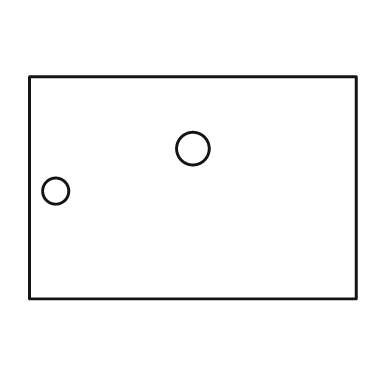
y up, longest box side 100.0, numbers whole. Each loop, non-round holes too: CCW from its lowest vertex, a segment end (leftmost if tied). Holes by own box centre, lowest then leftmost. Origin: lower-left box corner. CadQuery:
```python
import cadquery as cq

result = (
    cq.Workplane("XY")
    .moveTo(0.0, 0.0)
    .lineTo(100.0, 0.0)
    .lineTo(100.0, 68.0)
    .lineTo(0.0, 68.0)
    .close()
    .moveTo(8.0, 33.0)
    .circle(4.0)
    .moveTo(50.0, 46.0)
    .circle(5.0)
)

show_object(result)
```